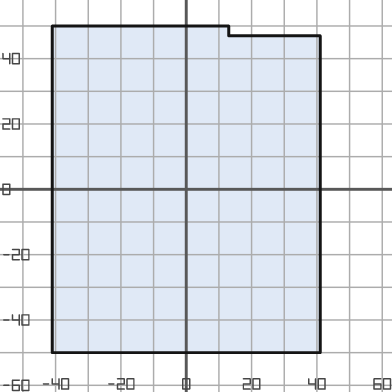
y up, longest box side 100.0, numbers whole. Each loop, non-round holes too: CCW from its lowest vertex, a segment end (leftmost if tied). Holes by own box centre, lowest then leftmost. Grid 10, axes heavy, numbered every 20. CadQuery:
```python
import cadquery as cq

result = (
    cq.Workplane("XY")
    .moveTo(-41.0, -50.0)
    .lineTo(41.0, -50.0)
    .lineTo(41.0, 47.0)
    .lineTo(13.0, 47.0)
    .lineTo(13.0, 50.0)
    .lineTo(-41.0, 50.0)
    .close()
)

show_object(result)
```